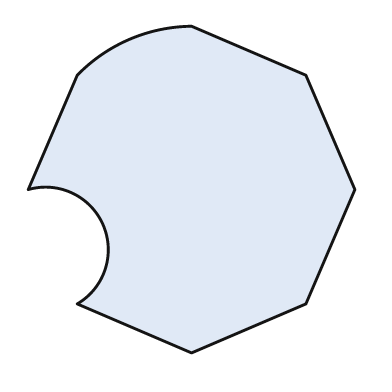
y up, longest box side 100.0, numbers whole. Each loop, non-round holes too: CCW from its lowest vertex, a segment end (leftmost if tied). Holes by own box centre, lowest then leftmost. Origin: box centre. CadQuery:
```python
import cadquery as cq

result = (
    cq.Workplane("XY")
    .moveTo(0.0, -50.0)
    .lineTo(35.0, -35.0)
    .lineTo(50.0, 0.0)
    .lineTo(35.0, 35.0)
    .lineTo(0.0, 50.0)
    .threePointArc((-19.0, 46.0), (-35.0, 35.0))
    .lineTo(-50.0, 0.0)
    .threePointArc((-27.0, -11.0), (-35.0, -35.0))
    .close()
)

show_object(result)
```